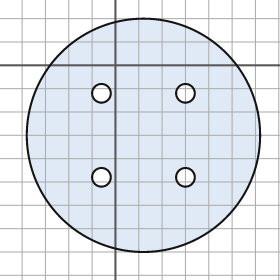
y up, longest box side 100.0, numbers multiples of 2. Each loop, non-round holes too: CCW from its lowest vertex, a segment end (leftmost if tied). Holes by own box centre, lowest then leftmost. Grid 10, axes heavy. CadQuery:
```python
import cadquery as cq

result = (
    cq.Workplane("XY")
    .moveTo(12.0, -30.0)
    .circle(50.0)
    .moveTo(-6.0, -48.0)
    .circle(4.0)
    .moveTo(30.0, -48.0)
    .circle(4.0)
    .moveTo(-6.0, -12.0)
    .circle(4.0)
    .moveTo(30.0, -12.0)
    .circle(4.0)
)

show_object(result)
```